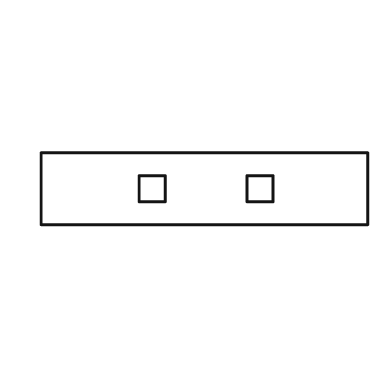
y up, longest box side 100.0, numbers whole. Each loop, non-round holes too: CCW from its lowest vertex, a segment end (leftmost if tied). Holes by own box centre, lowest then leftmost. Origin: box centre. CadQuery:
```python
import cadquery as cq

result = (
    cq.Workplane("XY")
    .moveTo(-50.0, -11.0)
    .lineTo(50.0, -11.0)
    .lineTo(50.0, 11.0)
    .lineTo(-50.0, 11.0)
    .close()
    .moveTo(-20.0, -4.0)
    .lineTo(-12.0, -4.0)
    .lineTo(-12.0, 4.0)
    .lineTo(-20.0, 4.0)
    .close()
    .moveTo(13.0, -4.0)
    .lineTo(21.0, -4.0)
    .lineTo(21.0, 4.0)
    .lineTo(13.0, 4.0)
    .close()
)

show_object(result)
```